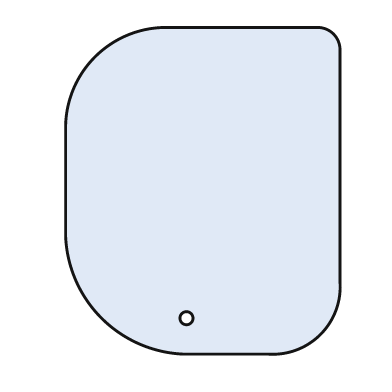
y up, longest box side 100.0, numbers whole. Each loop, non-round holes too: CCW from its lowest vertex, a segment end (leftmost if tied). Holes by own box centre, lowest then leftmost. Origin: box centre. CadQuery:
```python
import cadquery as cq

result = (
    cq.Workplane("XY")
    .moveTo(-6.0, -50.0)
    .lineTo(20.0, -50.0)
    .threePointArc((36.0, -44.0), (42.0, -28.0))
    .lineTo(42.0, 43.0)
    .threePointArc((40.0, 48.0), (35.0, 50.0))
    .lineTo(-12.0, 50.0)
    .threePointArc((-33.0, 41.0), (-42.0, 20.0))
    .lineTo(-42.0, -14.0)
    .threePointArc((-31.0, -39.0), (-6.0, -50.0))
    .close()
    .moveTo(-5.0, -39.0)
    .circle(2.0)
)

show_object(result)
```